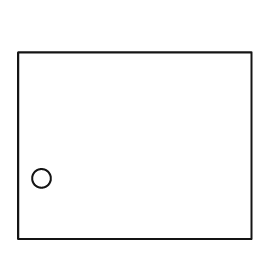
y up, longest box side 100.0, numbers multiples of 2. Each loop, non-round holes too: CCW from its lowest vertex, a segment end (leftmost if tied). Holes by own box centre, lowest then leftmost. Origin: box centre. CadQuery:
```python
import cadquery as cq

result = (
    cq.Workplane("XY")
    .moveTo(-50.0, -40.0)
    .lineTo(50.0, -40.0)
    .lineTo(50.0, 40.0)
    .lineTo(-50.0, 40.0)
    .close()
    .moveTo(-40.0, -14.0)
    .circle(4.0)
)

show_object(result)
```